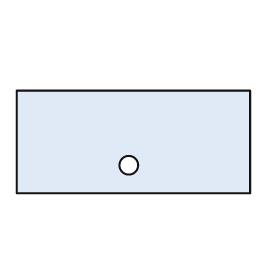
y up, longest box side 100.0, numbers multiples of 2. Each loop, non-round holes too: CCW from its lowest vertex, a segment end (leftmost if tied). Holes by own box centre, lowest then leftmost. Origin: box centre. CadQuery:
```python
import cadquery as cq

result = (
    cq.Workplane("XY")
    .moveTo(-50.0, -22.0)
    .lineTo(50.0, -22.0)
    .lineTo(50.0, 22.0)
    .lineTo(-50.0, 22.0)
    .close()
    .moveTo(-2.0, -10.0)
    .circle(4.0)
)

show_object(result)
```